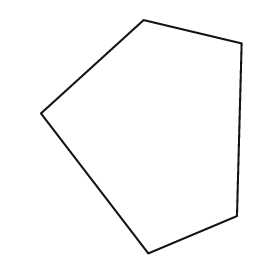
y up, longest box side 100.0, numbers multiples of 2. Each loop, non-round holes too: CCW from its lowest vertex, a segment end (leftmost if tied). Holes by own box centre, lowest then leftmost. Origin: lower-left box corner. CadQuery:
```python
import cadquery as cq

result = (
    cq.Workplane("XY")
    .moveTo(46.0, 0.0)
    .lineTo(84.0, 16.0)
    .lineTo(86.0, 90.0)
    .lineTo(44.0, 100.0)
    .lineTo(0.0, 60.0)
    .close()
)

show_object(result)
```